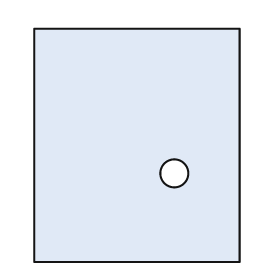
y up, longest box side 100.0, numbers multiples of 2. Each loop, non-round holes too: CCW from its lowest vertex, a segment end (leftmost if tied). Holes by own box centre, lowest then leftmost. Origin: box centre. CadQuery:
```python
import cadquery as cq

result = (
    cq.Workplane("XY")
    .moveTo(-44.0, -50.0)
    .lineTo(44.0, -50.0)
    .lineTo(44.0, 50.0)
    .lineTo(-44.0, 50.0)
    .close()
    .moveTo(16.0, -12.0)
    .circle(6.0)
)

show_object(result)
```